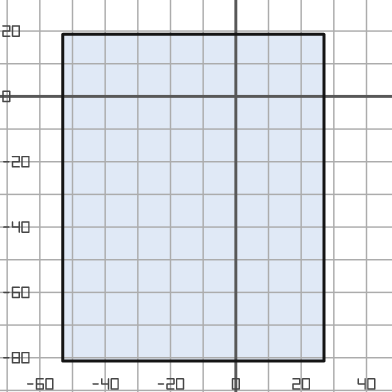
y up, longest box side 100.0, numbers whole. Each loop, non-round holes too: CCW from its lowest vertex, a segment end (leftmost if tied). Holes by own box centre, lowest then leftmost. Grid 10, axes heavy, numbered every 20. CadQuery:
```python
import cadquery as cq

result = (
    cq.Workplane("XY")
    .moveTo(-53.0, -81.0)
    .lineTo(27.0, -81.0)
    .lineTo(27.0, 19.0)
    .lineTo(-53.0, 19.0)
    .close()
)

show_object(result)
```